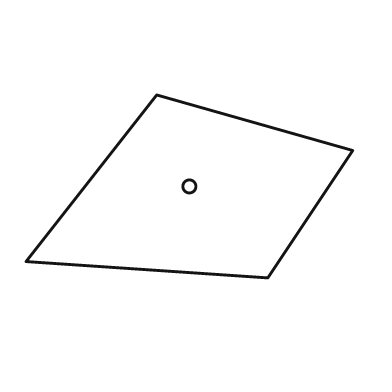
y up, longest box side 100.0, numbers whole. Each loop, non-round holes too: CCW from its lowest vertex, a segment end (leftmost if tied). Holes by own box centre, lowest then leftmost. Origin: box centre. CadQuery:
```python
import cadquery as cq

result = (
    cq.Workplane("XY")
    .moveTo(24.0, -28.0)
    .lineTo(50.0, 11.0)
    .lineTo(-10.0, 28.0)
    .lineTo(-50.0, -23.0)
    .close()
    .moveTo(0.0, 0.0)
    .circle(2.0)
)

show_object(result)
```